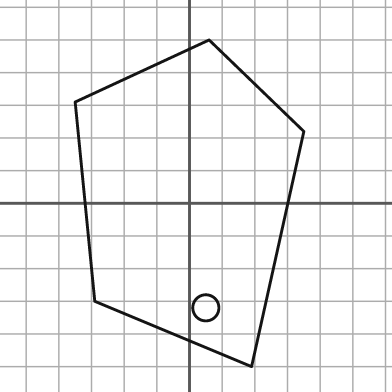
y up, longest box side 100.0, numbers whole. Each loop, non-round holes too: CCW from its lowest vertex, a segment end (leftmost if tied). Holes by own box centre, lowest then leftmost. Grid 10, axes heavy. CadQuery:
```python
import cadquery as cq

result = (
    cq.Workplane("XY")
    .moveTo(19.0, -50.0)
    .lineTo(35.0, 22.0)
    .lineTo(6.0, 50.0)
    .lineTo(-35.0, 31.0)
    .lineTo(-29.0, -30.0)
    .close()
    .moveTo(5.0, -32.0)
    .circle(4.0)
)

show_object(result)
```